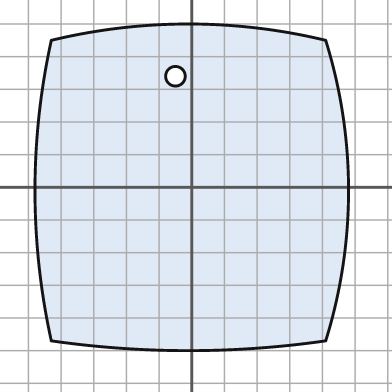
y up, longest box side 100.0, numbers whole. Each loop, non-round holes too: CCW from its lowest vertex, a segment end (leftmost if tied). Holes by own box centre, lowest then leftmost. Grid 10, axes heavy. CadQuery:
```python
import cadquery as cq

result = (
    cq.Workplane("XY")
    .moveTo(-43.0, -47.0)
    .threePointArc((-1.0, -50.0), (41.0, -47.0))
    .threePointArc((48.0, -1.0), (41.0, 45.0))
    .threePointArc((-1.0, 50.0), (-43.0, 45.0))
    .threePointArc((-48.0, -1.0), (-43.0, -47.0))
    .close()
    .moveTo(-5.0, 34.0)
    .circle(3.0)
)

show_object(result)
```